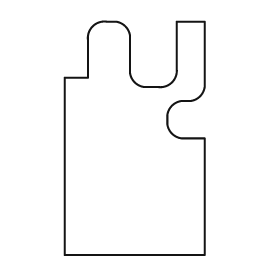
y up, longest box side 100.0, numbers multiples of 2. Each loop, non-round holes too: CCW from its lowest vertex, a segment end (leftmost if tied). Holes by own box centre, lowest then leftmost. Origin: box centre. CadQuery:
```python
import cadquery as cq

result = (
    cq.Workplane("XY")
    .moveTo(-30.0, -50.0)
    .lineTo(30.0, -50.0)
    .lineTo(30.0, 0.0)
    .lineTo(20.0, 0.0)
    .threePointArc((16.0, 2.0), (14.0, 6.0))
    .lineTo(14.0, 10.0)
    .threePointArc((16.0, 14.0), (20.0, 16.0))
    .lineTo(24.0, 16.0)
    .threePointArc((28.0, 18.0), (30.0, 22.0))
    .lineTo(30.0, 50.0)
    .lineTo(18.0, 50.0)
    .lineTo(18.0, 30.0)
    .threePointArc((16.0, 24.0), (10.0, 22.0))
    .lineTo(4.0, 22.0)
    .threePointArc((0.0, 24.0), (-2.0, 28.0))
    .lineTo(-2.0, 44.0)
    .threePointArc((-4.0, 48.0), (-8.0, 50.0))
    .lineTo(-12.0, 50.0)
    .threePointArc((-18.0, 48.0), (-20.0, 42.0))
    .lineTo(-20.0, 26.0)
    .lineTo(-30.0, 26.0)
    .close()
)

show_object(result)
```